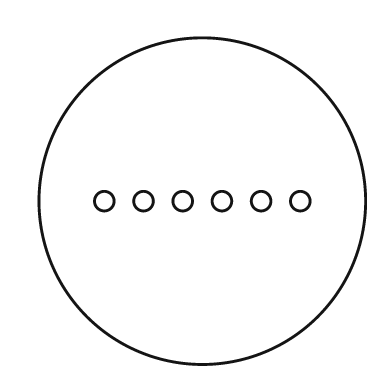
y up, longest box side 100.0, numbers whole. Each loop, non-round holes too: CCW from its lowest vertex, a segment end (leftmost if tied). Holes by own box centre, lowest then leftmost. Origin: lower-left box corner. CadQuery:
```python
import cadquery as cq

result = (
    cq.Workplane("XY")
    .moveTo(50.0, 50.0)
    .circle(50.0)
    .moveTo(20.0, 50.0)
    .circle(3.0)
    .moveTo(32.0, 50.0)
    .circle(3.0)
    .moveTo(44.0, 50.0)
    .circle(3.0)
    .moveTo(56.0, 50.0)
    .circle(3.0)
    .moveTo(68.0, 50.0)
    .circle(3.0)
    .moveTo(80.0, 50.0)
    .circle(3.0)
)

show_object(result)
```